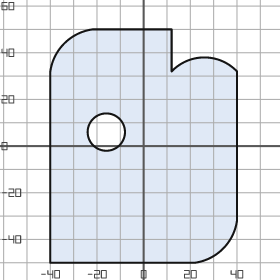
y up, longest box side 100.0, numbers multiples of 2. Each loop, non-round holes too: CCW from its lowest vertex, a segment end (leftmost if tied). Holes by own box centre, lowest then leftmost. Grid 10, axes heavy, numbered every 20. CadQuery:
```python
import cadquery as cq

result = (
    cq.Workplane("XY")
    .moveTo(-40.0, -50.0)
    .lineTo(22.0, -50.0)
    .threePointArc((34.0, -44.0), (40.0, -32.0))
    .lineTo(40.0, 32.0)
    .threePointArc((26.0, 38.0), (12.0, 32.0))
    .lineTo(12.0, 50.0)
    .lineTo(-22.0, 50.0)
    .threePointArc((-34.0, 44.0), (-40.0, 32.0))
    .close()
    .moveTo(-16.0, 6.0)
    .circle(8.0)
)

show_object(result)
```